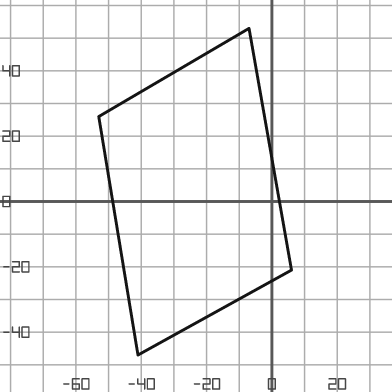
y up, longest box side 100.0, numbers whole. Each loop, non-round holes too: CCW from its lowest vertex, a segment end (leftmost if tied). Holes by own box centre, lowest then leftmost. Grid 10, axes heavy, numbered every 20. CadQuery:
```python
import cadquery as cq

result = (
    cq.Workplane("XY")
    .moveTo(-41.0, -47.0)
    .lineTo(6.0, -21.0)
    .lineTo(-7.0, 53.0)
    .lineTo(-53.0, 26.0)
    .close()
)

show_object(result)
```